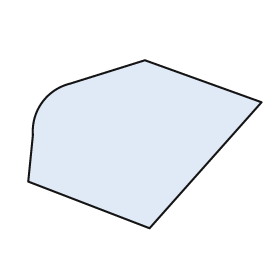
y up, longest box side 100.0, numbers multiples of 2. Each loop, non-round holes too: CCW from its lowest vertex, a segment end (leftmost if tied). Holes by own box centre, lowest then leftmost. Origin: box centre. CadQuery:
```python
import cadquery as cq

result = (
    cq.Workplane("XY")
    .moveTo(2.0, -36.0)
    .lineTo(50.0, 18.0)
    .lineTo(0.0, 36.0)
    .lineTo(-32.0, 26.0)
    .threePointArc((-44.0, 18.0), (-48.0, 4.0))
    .lineTo(-50.0, -16.0)
    .close()
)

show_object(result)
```